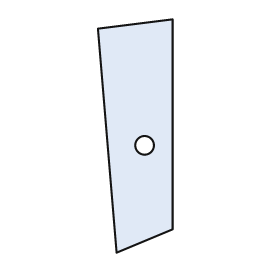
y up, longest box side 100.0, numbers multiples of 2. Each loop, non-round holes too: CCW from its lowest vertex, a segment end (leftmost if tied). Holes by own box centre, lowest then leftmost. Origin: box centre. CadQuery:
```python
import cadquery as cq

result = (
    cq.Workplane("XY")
    .moveTo(-8.0, -50.0)
    .lineTo(16.0, -40.0)
    .lineTo(16.0, 50.0)
    .lineTo(-16.0, 46.0)
    .close()
    .moveTo(4.0, -4.0)
    .circle(4.0)
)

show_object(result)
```